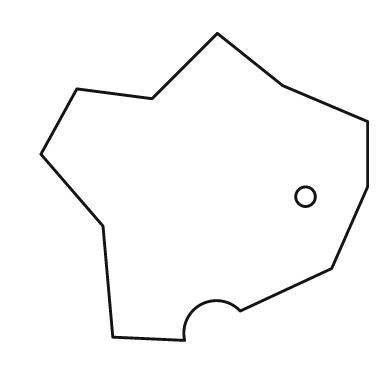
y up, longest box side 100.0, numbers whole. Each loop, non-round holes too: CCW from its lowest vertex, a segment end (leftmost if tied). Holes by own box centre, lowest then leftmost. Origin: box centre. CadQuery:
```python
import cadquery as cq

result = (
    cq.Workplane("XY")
    .moveTo(-6.0, -47.0)
    .threePointArc((-1.0, -36.0), (11.0, -38.0))
    .lineTo(39.0, -25.0)
    .lineTo(50.0, 0.0)
    .lineTo(50.0, 20.0)
    .lineTo(24.0, 31.0)
    .lineTo(4.0, 47.0)
    .lineTo(-16.0, 27.0)
    .lineTo(-39.0, 30.0)
    .lineTo(-50.0, 10.0)
    .lineTo(-31.0, -12.0)
    .lineTo(-28.0, -46.0)
    .close()
    .moveTo(31.0, -3.0)
    .circle(3.0)
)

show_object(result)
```